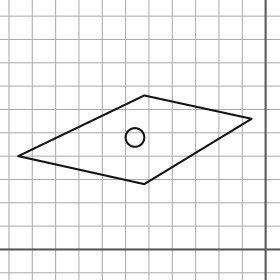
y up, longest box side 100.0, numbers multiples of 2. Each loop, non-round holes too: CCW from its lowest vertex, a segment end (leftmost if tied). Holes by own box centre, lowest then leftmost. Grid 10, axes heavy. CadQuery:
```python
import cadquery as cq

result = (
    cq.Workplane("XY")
    .moveTo(-52.0, 28.0)
    .lineTo(-6.0, 56.0)
    .lineTo(-52.0, 66.0)
    .lineTo(-106.0, 40.0)
    .close()
    .moveTo(-56.0, 48.0)
    .circle(4.0)
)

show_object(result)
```